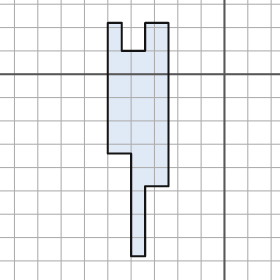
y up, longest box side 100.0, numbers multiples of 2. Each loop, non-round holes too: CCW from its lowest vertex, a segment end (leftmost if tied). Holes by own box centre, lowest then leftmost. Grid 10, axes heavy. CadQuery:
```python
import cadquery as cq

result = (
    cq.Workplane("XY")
    .moveTo(-40.0, -78.0)
    .lineTo(-34.0, -78.0)
    .lineTo(-34.0, -48.0)
    .lineTo(-24.0, -48.0)
    .lineTo(-24.0, 22.0)
    .lineTo(-34.0, 22.0)
    .lineTo(-34.0, 10.0)
    .lineTo(-44.0, 10.0)
    .lineTo(-44.0, 22.0)
    .lineTo(-50.0, 22.0)
    .lineTo(-50.0, -34.0)
    .lineTo(-40.0, -34.0)
    .close()
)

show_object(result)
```